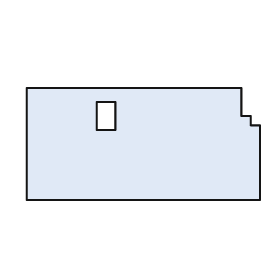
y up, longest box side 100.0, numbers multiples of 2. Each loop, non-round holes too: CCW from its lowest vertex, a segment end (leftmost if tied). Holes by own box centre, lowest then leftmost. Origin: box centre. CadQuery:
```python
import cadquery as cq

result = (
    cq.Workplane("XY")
    .moveTo(-50.0, -24.0)
    .lineTo(50.0, -24.0)
    .lineTo(50.0, 8.0)
    .lineTo(46.0, 8.0)
    .lineTo(46.0, 12.0)
    .lineTo(42.0, 12.0)
    .lineTo(42.0, 24.0)
    .lineTo(-50.0, 24.0)
    .close()
    .moveTo(-20.0, 6.0)
    .lineTo(-12.0, 6.0)
    .lineTo(-12.0, 18.0)
    .lineTo(-20.0, 18.0)
    .close()
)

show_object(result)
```